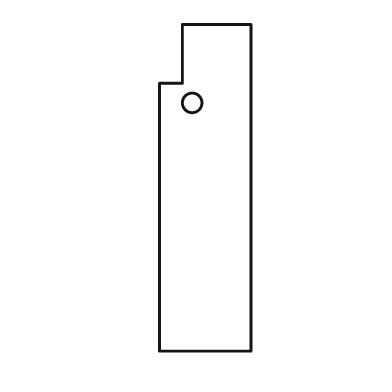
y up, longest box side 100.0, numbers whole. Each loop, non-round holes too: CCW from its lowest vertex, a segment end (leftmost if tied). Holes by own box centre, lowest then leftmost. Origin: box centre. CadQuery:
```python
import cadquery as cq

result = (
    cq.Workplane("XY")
    .moveTo(-14.0, -50.0)
    .lineTo(14.0, -50.0)
    .lineTo(14.0, 50.0)
    .lineTo(-7.0, 50.0)
    .lineTo(-7.0, 32.0)
    .lineTo(-14.0, 32.0)
    .close()
    .moveTo(-4.0, 26.0)
    .circle(3.0)
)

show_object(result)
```